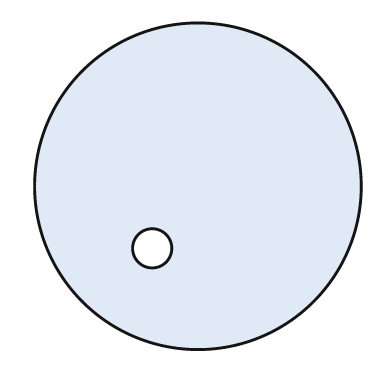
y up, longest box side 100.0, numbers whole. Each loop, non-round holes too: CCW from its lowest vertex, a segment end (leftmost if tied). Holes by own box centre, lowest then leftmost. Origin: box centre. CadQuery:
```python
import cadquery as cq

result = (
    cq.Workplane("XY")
    .moveTo(0.0, 0.0)
    .circle(50.0)
    .moveTo(-14.0, -19.0)
    .circle(6.0)
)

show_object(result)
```